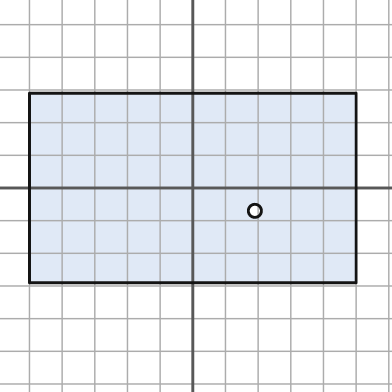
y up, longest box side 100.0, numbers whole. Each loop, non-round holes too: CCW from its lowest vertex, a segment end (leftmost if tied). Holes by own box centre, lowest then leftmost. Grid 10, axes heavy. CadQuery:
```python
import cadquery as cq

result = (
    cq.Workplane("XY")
    .moveTo(-50.0, -29.0)
    .lineTo(50.0, -29.0)
    .lineTo(50.0, 29.0)
    .lineTo(-50.0, 29.0)
    .close()
    .moveTo(19.0, -7.0)
    .circle(2.0)
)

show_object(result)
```